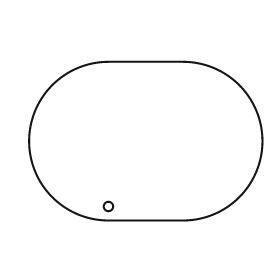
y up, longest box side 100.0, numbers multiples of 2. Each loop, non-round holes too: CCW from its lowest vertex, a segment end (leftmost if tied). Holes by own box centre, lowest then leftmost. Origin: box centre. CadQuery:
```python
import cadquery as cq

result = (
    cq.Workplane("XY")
    .moveTo(-16.0, -34.0)
    .lineTo(16.0, -34.0)
    .threePointArc((50.0, 0.0), (16.0, 34.0))
    .lineTo(-16.0, 34.0)
    .threePointArc((-50.0, 0.0), (-16.0, -34.0))
    .close()
    .moveTo(-16.0, -28.0)
    .circle(2.0)
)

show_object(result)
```